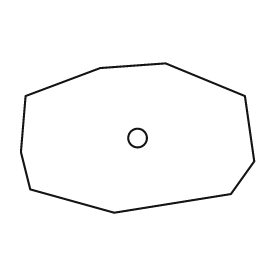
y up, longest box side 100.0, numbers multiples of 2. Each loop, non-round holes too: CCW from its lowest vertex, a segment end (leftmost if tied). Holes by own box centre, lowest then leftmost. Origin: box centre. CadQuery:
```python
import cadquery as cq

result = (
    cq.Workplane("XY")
    .moveTo(-10.0, -32.0)
    .lineTo(40.0, -24.0)
    .lineTo(50.0, -10.0)
    .lineTo(46.0, 18.0)
    .lineTo(12.0, 32.0)
    .lineTo(-16.0, 30.0)
    .lineTo(-48.0, 18.0)
    .lineTo(-50.0, -6.0)
    .lineTo(-46.0, -22.0)
    .close()
    .moveTo(0.0, 0.0)
    .circle(4.0)
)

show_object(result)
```